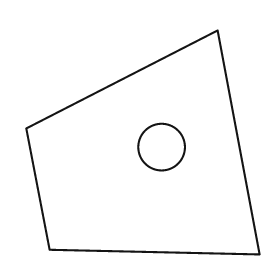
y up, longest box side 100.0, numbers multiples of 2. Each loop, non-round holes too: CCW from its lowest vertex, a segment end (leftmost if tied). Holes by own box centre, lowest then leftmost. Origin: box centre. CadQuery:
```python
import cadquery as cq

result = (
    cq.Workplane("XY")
    .moveTo(50.0, -48.0)
    .lineTo(32.0, 48.0)
    .lineTo(-50.0, 6.0)
    .lineTo(-40.0, -46.0)
    .close()
    .moveTo(8.0, -2.0)
    .circle(10.0)
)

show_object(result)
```